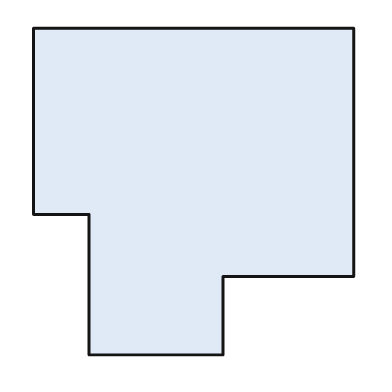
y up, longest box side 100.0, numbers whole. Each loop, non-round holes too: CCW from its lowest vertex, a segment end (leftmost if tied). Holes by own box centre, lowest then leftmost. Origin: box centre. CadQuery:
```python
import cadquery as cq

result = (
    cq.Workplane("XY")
    .moveTo(-32.0, -50.0)
    .lineTo(9.0, -50.0)
    .lineTo(9.0, -26.0)
    .lineTo(49.0, -26.0)
    .lineTo(49.0, 50.0)
    .lineTo(-49.0, 50.0)
    .lineTo(-49.0, -7.0)
    .lineTo(-32.0, -7.0)
    .close()
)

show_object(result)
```